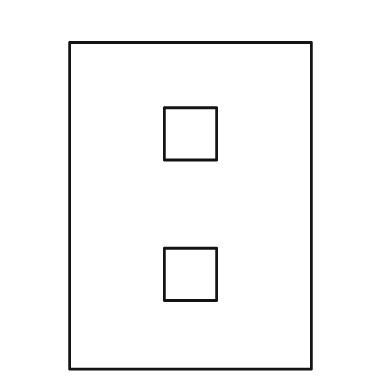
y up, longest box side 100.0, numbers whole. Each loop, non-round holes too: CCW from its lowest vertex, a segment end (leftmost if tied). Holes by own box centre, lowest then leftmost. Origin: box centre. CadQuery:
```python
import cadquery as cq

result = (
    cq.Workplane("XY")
    .moveTo(-37.0, -50.0)
    .lineTo(37.0, -50.0)
    .lineTo(37.0, 50.0)
    .lineTo(-37.0, 50.0)
    .close()
    .moveTo(-8.0, -29.0)
    .lineTo(8.0, -29.0)
    .lineTo(8.0, -13.0)
    .lineTo(-8.0, -13.0)
    .close()
    .moveTo(-8.0, 14.0)
    .lineTo(8.0, 14.0)
    .lineTo(8.0, 30.0)
    .lineTo(-8.0, 30.0)
    .close()
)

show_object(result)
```